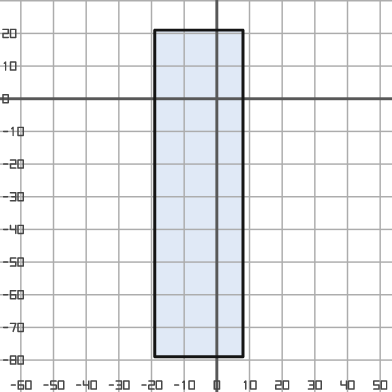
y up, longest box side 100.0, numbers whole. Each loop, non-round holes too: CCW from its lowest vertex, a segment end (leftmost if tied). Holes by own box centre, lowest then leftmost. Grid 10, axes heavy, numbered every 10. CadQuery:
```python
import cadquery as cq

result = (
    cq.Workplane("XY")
    .moveTo(-19.0, -79.0)
    .lineTo(8.0, -79.0)
    .lineTo(8.0, 21.0)
    .lineTo(-19.0, 21.0)
    .close()
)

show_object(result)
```